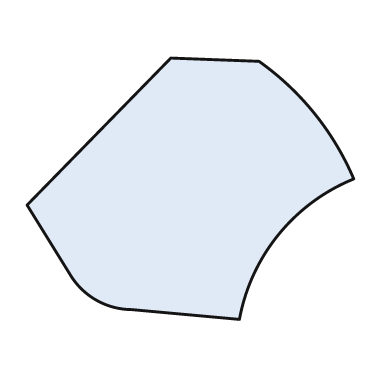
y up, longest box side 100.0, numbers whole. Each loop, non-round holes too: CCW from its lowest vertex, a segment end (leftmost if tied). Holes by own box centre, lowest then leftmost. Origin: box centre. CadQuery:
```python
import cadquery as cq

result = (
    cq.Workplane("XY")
    .moveTo(15.0, -40.0)
    .threePointArc((27.0, -14.0), (50.0, 3.0))
    .threePointArc((38.0, 23.0), (21.0, 39.0))
    .lineTo(-6.0, 40.0)
    .lineTo(-50.0, -5.0)
    .lineTo(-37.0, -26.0)
    .threePointArc((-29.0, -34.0), (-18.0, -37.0))
    .close()
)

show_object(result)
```